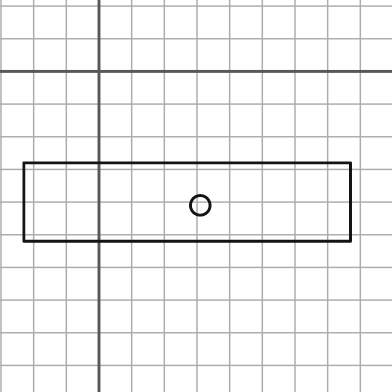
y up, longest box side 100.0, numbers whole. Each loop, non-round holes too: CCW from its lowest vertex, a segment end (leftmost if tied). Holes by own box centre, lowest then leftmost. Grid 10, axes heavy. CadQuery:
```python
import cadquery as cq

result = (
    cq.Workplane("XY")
    .moveTo(-23.0, -52.0)
    .lineTo(77.0, -52.0)
    .lineTo(77.0, -28.0)
    .lineTo(-23.0, -28.0)
    .close()
    .moveTo(31.0, -41.0)
    .circle(3.0)
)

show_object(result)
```